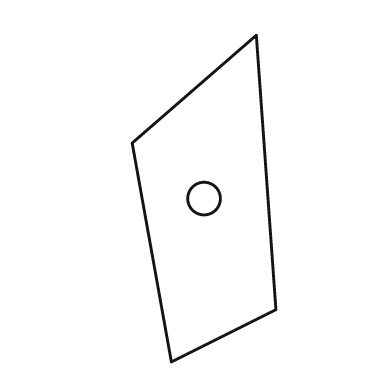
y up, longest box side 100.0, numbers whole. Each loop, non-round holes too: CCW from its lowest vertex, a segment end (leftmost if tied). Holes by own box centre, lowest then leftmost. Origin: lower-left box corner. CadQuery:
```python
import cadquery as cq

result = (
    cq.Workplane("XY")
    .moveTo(12.0, 0.0)
    .lineTo(44.0, 16.0)
    .lineTo(38.0, 100.0)
    .lineTo(0.0, 67.0)
    .close()
    .moveTo(22.0, 50.0)
    .circle(5.0)
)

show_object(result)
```